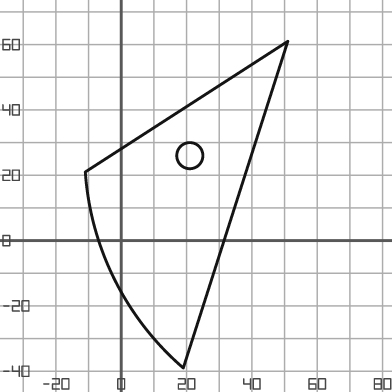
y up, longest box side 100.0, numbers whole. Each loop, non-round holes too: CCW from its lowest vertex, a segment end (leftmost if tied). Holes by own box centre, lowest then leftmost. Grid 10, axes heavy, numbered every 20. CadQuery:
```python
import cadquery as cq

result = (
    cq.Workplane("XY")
    .moveTo(19.0, -39.0)
    .lineTo(51.0, 61.0)
    .lineTo(-11.0, 21.0)
    .threePointArc((-2.0, -12.0), (19.0, -39.0))
    .close()
    .moveTo(21.0, 26.0)
    .circle(4.0)
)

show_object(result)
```